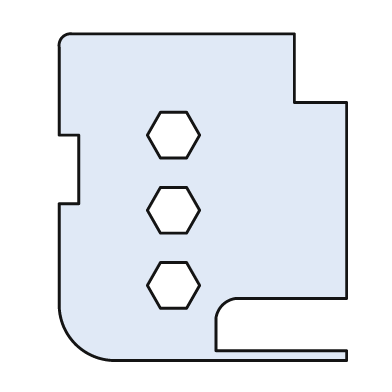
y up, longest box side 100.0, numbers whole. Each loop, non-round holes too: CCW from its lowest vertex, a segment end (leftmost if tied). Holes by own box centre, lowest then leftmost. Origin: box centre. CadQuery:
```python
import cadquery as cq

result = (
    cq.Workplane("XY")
    .moveTo(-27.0, -50.0)
    .lineTo(44.0, -50.0)
    .lineTo(44.0, -47.0)
    .lineTo(4.0, -47.0)
    .lineTo(4.0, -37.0)
    .threePointArc((6.0, -33.0), (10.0, -31.0))
    .lineTo(44.0, -31.0)
    .lineTo(44.0, 29.0)
    .lineTo(28.0, 29.0)
    .lineTo(28.0, 50.0)
    .lineTo(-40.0, 50.0)
    .threePointArc((-43.0, 49.0), (-44.0, 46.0))
    .lineTo(-44.0, 19.0)
    .lineTo(-38.0, 19.0)
    .lineTo(-38.0, -2.0)
    .lineTo(-44.0, -2.0)
    .lineTo(-44.0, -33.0)
    .threePointArc((-39.0, -45.0), (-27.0, -50.0))
    .close()
    .moveTo(-13.0, -34.0)
    .lineTo(-5.0, -34.0)
    .lineTo(-1.0, -27.0)
    .lineTo(-5.0, -20.0)
    .lineTo(-13.0, -20.0)
    .lineTo(-17.0, -27.0)
    .close()
    .moveTo(-13.0, -11.0)
    .lineTo(-5.0, -11.0)
    .lineTo(-1.0, -4.0)
    .lineTo(-5.0, 3.0)
    .lineTo(-13.0, 3.0)
    .lineTo(-17.0, -4.0)
    .close()
    .moveTo(-13.0, 12.0)
    .lineTo(-5.0, 12.0)
    .lineTo(-1.0, 19.0)
    .lineTo(-5.0, 26.0)
    .lineTo(-13.0, 26.0)
    .lineTo(-17.0, 19.0)
    .close()
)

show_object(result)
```